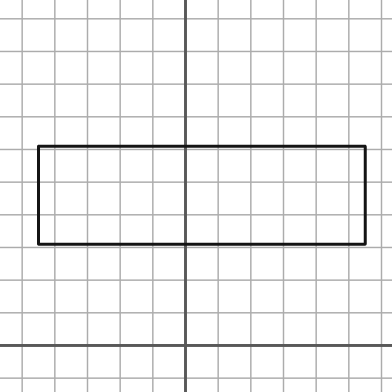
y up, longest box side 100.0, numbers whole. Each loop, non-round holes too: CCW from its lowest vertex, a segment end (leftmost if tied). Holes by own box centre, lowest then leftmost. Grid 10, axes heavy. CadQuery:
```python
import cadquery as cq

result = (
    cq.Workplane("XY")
    .moveTo(-45.0, 31.0)
    .lineTo(55.0, 31.0)
    .lineTo(55.0, 61.0)
    .lineTo(-45.0, 61.0)
    .close()
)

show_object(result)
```